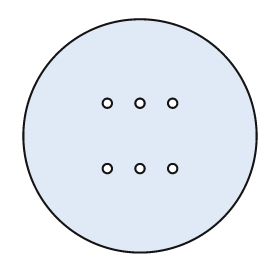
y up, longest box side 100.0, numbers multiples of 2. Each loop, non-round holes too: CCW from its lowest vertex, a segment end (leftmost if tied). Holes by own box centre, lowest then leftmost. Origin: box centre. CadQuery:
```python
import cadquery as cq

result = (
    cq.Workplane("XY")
    .moveTo(0.0, 0.0)
    .circle(50.0)
    .moveTo(-14.0, -14.0)
    .circle(2.0)
    .moveTo(0.0, -14.0)
    .circle(2.0)
    .moveTo(14.0, -14.0)
    .circle(2.0)
    .moveTo(-14.0, 14.0)
    .circle(2.0)
    .moveTo(0.0, 14.0)
    .circle(2.0)
    .moveTo(14.0, 14.0)
    .circle(2.0)
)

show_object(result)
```